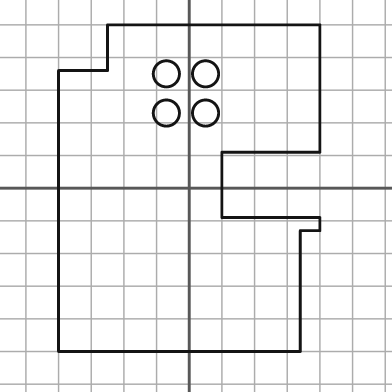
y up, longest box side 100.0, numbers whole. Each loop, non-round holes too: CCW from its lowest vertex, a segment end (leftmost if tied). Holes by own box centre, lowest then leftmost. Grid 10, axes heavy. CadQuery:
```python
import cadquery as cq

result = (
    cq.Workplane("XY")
    .moveTo(-40.0, -50.0)
    .lineTo(34.0, -50.0)
    .lineTo(34.0, -13.0)
    .lineTo(40.0, -13.0)
    .lineTo(40.0, -9.0)
    .lineTo(10.0, -9.0)
    .lineTo(10.0, 11.0)
    .lineTo(40.0, 11.0)
    .lineTo(40.0, 50.0)
    .lineTo(-25.0, 50.0)
    .lineTo(-25.0, 36.0)
    .lineTo(-40.0, 36.0)
    .close()
    .moveTo(-7.0, 23.0)
    .circle(4.0)
    .moveTo(5.0, 23.0)
    .circle(4.0)
    .moveTo(-7.0, 35.0)
    .circle(4.0)
    .moveTo(5.0, 35.0)
    .circle(4.0)
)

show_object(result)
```